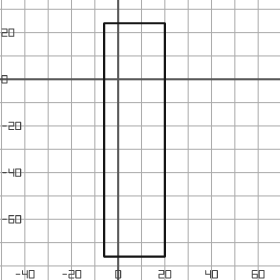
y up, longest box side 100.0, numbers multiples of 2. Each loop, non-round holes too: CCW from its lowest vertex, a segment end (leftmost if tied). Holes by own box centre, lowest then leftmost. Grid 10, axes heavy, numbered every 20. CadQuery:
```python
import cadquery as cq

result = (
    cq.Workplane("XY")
    .moveTo(-6.0, -76.0)
    .lineTo(20.0, -76.0)
    .lineTo(20.0, 24.0)
    .lineTo(-6.0, 24.0)
    .close()
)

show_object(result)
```